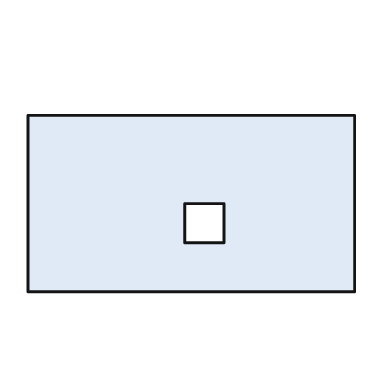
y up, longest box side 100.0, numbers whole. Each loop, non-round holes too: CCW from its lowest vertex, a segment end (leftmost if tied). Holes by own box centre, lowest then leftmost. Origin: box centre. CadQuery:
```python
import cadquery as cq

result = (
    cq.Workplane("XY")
    .moveTo(-50.0, -27.0)
    .lineTo(50.0, -27.0)
    .lineTo(50.0, 27.0)
    .lineTo(-50.0, 27.0)
    .close()
    .moveTo(-2.0, -12.0)
    .lineTo(10.0, -12.0)
    .lineTo(10.0, 0.0)
    .lineTo(-2.0, 0.0)
    .close()
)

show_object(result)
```